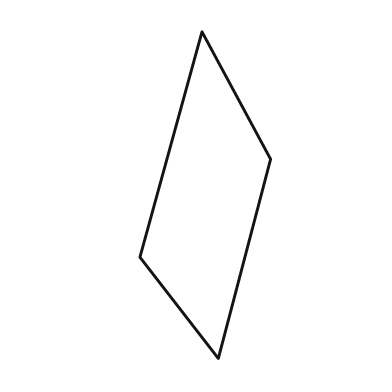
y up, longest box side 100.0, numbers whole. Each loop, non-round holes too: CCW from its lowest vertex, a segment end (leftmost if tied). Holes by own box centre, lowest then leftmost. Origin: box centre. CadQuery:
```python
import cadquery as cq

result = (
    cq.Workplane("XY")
    .moveTo(4.0, -50.0)
    .lineTo(20.0, 11.0)
    .lineTo(-1.0, 50.0)
    .lineTo(-20.0, -19.0)
    .close()
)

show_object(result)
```